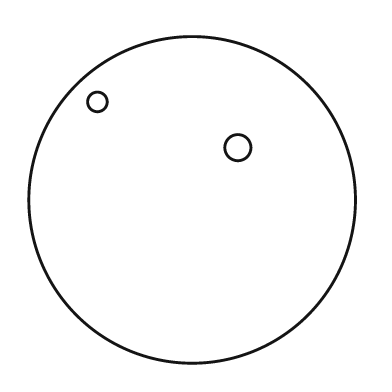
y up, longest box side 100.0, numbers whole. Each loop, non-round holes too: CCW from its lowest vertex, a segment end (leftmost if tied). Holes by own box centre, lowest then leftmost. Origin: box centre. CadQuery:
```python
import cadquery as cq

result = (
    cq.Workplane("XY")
    .moveTo(0.0, 0.0)
    .circle(50.0)
    .moveTo(14.0, 16.0)
    .circle(4.0)
    .moveTo(-29.0, 30.0)
    .circle(3.0)
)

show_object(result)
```